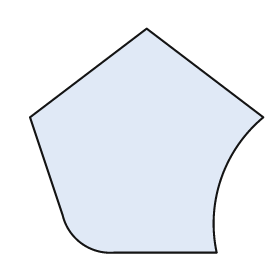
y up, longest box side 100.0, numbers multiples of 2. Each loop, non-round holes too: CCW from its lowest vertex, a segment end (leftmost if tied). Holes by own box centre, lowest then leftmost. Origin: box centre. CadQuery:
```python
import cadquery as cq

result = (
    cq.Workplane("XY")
    .moveTo(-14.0, -48.0)
    .lineTo(30.0, -48.0)
    .threePointArc((32.0, -16.0), (50.0, 10.0))
    .lineTo(0.0, 48.0)
    .lineTo(-50.0, 10.0)
    .lineTo(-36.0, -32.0)
    .threePointArc((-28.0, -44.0), (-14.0, -48.0))
    .close()
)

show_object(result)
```